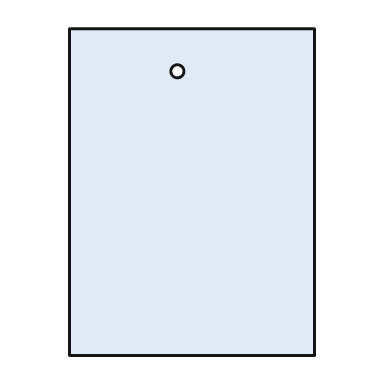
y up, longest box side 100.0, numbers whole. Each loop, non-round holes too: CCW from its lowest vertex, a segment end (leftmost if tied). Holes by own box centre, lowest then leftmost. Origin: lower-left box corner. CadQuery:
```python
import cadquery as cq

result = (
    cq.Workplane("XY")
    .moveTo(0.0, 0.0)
    .lineTo(75.0, 0.0)
    .lineTo(75.0, 100.0)
    .lineTo(0.0, 100.0)
    .close()
    .moveTo(33.0, 87.0)
    .circle(2.0)
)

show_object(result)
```